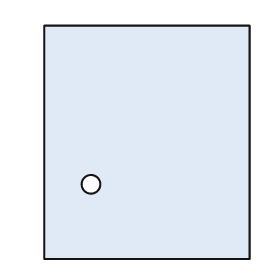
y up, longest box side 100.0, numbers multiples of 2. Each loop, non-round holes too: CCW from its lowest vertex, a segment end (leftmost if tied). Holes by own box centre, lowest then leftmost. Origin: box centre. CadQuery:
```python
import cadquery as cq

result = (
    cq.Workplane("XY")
    .moveTo(-44.0, -50.0)
    .lineTo(44.0, -50.0)
    .lineTo(44.0, 50.0)
    .lineTo(-44.0, 50.0)
    .close()
    .moveTo(-24.0, -18.0)
    .circle(4.0)
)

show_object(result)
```